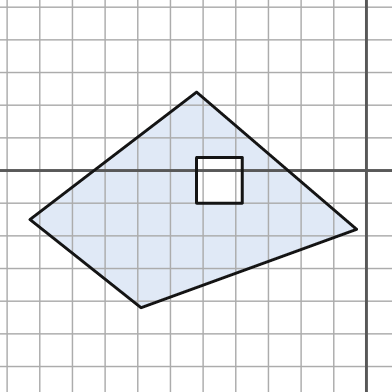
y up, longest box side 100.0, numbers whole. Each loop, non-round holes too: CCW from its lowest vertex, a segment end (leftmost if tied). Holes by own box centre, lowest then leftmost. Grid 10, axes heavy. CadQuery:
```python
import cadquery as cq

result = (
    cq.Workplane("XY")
    .moveTo(-69.0, -42.0)
    .lineTo(-3.0, -18.0)
    .lineTo(-52.0, 24.0)
    .lineTo(-103.0, -15.0)
    .close()
    .moveTo(-52.0, -10.0)
    .lineTo(-38.0, -10.0)
    .lineTo(-38.0, 4.0)
    .lineTo(-52.0, 4.0)
    .close()
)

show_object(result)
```